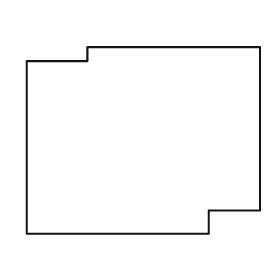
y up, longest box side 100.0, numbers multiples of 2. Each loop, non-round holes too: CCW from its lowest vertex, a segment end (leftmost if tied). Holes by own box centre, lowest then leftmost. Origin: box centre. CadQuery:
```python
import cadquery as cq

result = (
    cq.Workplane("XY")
    .moveTo(-50.0, -40.0)
    .lineTo(28.0, -40.0)
    .lineTo(28.0, -30.0)
    .lineTo(50.0, -30.0)
    .lineTo(50.0, 40.0)
    .lineTo(-24.0, 40.0)
    .lineTo(-24.0, 34.0)
    .lineTo(-50.0, 34.0)
    .close()
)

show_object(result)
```